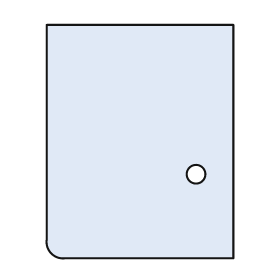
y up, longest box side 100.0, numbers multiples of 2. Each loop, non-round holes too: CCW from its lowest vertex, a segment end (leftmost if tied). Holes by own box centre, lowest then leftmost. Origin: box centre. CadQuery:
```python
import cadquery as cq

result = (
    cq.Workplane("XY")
    .moveTo(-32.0, -50.0)
    .lineTo(40.0, -50.0)
    .lineTo(40.0, 50.0)
    .lineTo(-40.0, 50.0)
    .lineTo(-40.0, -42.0)
    .threePointArc((-38.0, -48.0), (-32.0, -50.0))
    .close()
    .moveTo(24.0, -14.0)
    .circle(4.0)
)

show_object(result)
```